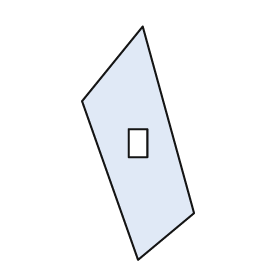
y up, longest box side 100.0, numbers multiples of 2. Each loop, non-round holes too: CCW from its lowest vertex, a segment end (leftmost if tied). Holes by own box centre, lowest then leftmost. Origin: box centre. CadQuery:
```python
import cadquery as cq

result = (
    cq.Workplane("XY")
    .moveTo(0.0, -50.0)
    .lineTo(24.0, -30.0)
    .lineTo(2.0, 50.0)
    .lineTo(-24.0, 18.0)
    .close()
    .moveTo(-4.0, -6.0)
    .lineTo(4.0, -6.0)
    .lineTo(4.0, 6.0)
    .lineTo(-4.0, 6.0)
    .close()
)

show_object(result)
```